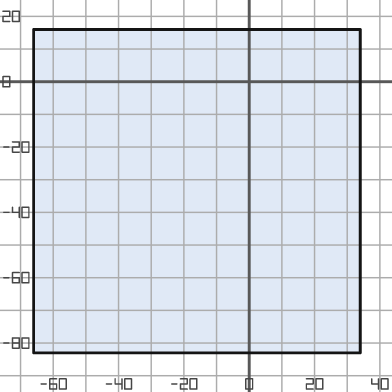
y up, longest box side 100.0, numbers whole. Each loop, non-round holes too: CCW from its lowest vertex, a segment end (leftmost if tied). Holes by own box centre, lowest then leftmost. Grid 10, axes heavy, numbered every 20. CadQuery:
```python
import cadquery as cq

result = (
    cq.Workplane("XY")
    .moveTo(-66.0, -83.0)
    .lineTo(34.0, -83.0)
    .lineTo(34.0, 16.0)
    .lineTo(-66.0, 16.0)
    .close()
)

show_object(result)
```